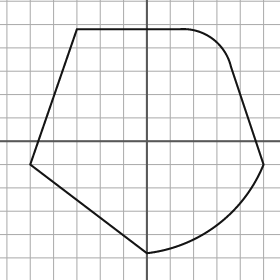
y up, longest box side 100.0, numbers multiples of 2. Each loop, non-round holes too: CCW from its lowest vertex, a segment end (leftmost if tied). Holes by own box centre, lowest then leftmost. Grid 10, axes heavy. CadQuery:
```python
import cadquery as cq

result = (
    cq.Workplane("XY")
    .moveTo(0.0, -48.0)
    .threePointArc((30.0, -36.0), (50.0, -10.0))
    .lineTo(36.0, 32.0)
    .threePointArc((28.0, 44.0), (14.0, 48.0))
    .lineTo(-30.0, 48.0)
    .lineTo(-50.0, -10.0)
    .close()
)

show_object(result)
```